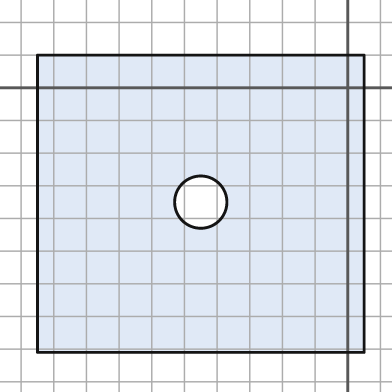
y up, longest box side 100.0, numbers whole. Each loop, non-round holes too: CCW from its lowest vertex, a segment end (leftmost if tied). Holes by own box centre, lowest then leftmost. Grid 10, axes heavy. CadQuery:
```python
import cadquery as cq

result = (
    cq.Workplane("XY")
    .moveTo(-95.0, -81.0)
    .lineTo(5.0, -81.0)
    .lineTo(5.0, 10.0)
    .lineTo(-95.0, 10.0)
    .close()
    .moveTo(-45.0, -35.0)
    .circle(8.0)
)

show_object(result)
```